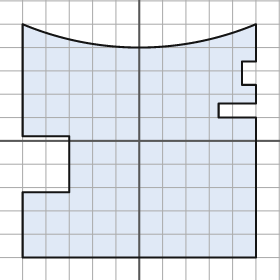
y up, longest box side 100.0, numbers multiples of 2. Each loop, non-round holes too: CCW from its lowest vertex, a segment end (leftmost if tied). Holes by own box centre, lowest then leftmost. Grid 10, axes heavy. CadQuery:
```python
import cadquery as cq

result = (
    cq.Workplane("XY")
    .moveTo(-50.0, -50.0)
    .lineTo(50.0, -50.0)
    .lineTo(50.0, 10.0)
    .lineTo(34.0, 10.0)
    .lineTo(34.0, 16.0)
    .lineTo(50.0, 16.0)
    .lineTo(50.0, 24.0)
    .lineTo(44.0, 24.0)
    .lineTo(44.0, 34.0)
    .lineTo(50.0, 34.0)
    .lineTo(50.0, 50.0)
    .threePointArc((0.0, 40.0), (-50.0, 50.0))
    .lineTo(-50.0, 2.0)
    .lineTo(-30.0, 2.0)
    .lineTo(-30.0, -22.0)
    .lineTo(-50.0, -22.0)
    .close()
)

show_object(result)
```